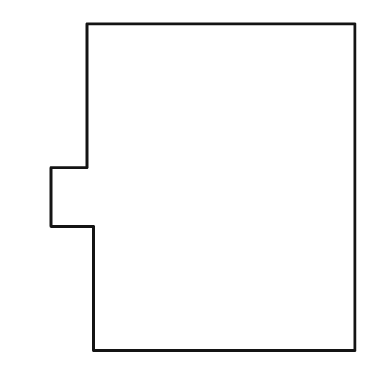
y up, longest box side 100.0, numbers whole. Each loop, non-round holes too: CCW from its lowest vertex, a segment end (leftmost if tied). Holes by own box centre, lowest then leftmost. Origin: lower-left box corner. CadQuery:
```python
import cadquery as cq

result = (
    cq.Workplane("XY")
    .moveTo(13.0, 0.0)
    .lineTo(93.0, 0.0)
    .lineTo(93.0, 100.0)
    .lineTo(11.0, 100.0)
    .lineTo(11.0, 56.0)
    .lineTo(0.0, 56.0)
    .lineTo(0.0, 38.0)
    .lineTo(13.0, 38.0)
    .close()
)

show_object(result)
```